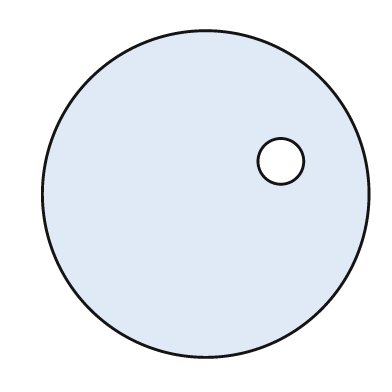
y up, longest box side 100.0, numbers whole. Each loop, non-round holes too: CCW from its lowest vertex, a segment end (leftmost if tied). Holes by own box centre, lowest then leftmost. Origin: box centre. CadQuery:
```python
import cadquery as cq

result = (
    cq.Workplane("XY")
    .moveTo(0.0, 0.0)
    .circle(50.0)
    .moveTo(23.0, 10.0)
    .circle(7.0)
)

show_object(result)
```